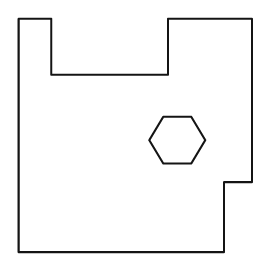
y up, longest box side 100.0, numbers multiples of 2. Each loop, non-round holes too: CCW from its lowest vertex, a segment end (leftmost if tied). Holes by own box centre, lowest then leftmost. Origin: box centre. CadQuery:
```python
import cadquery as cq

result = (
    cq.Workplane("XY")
    .moveTo(-50.0, -50.0)
    .lineTo(38.0, -50.0)
    .lineTo(38.0, -20.0)
    .lineTo(50.0, -20.0)
    .lineTo(50.0, 50.0)
    .lineTo(14.0, 50.0)
    .lineTo(14.0, 26.0)
    .lineTo(-36.0, 26.0)
    .lineTo(-36.0, 50.0)
    .lineTo(-50.0, 50.0)
    .close()
    .moveTo(12.0, -12.0)
    .lineTo(24.0, -12.0)
    .lineTo(30.0, -2.0)
    .lineTo(24.0, 8.0)
    .lineTo(12.0, 8.0)
    .lineTo(6.0, -2.0)
    .close()
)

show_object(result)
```